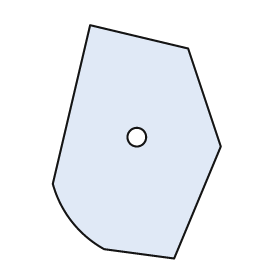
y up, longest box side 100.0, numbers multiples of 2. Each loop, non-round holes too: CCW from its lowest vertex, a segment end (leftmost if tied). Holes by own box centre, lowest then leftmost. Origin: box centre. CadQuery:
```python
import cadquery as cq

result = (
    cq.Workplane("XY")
    .moveTo(16.0, -50.0)
    .lineTo(36.0, -2.0)
    .lineTo(22.0, 40.0)
    .lineTo(-20.0, 50.0)
    .lineTo(-36.0, -18.0)
    .threePointArc((-28.0, -34.0), (-14.0, -46.0))
    .close()
    .moveTo(0.0, 2.0)
    .circle(4.0)
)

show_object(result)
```